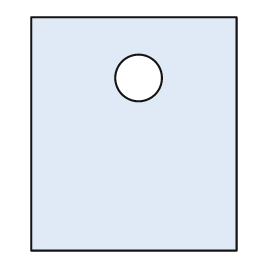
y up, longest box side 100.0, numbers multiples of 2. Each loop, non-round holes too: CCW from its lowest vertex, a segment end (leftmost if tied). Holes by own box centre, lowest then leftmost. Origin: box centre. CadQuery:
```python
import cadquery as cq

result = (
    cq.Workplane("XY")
    .moveTo(-44.0, -50.0)
    .lineTo(44.0, -50.0)
    .lineTo(44.0, 50.0)
    .lineTo(-44.0, 50.0)
    .close()
    .moveTo(2.0, 24.0)
    .circle(10.0)
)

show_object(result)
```